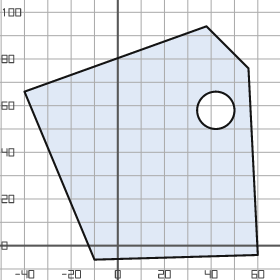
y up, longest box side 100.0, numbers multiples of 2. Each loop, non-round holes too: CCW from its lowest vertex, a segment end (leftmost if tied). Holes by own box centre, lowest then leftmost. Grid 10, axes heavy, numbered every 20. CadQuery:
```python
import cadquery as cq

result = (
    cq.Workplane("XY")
    .moveTo(-10.0, -6.0)
    .lineTo(60.0, -4.0)
    .lineTo(56.0, 76.0)
    .lineTo(38.0, 94.0)
    .lineTo(-40.0, 66.0)
    .close()
    .moveTo(42.0, 58.0)
    .circle(8.0)
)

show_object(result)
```